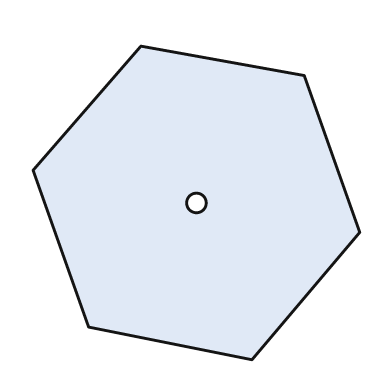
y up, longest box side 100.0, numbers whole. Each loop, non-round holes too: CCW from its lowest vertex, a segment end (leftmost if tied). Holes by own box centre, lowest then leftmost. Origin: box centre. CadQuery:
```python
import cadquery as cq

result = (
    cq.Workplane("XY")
    .moveTo(17.0, -48.0)
    .lineTo(50.0, -9.0)
    .lineTo(33.0, 39.0)
    .lineTo(-17.0, 48.0)
    .lineTo(-50.0, 10.0)
    .lineTo(-33.0, -38.0)
    .close()
    .moveTo(0.0, 0.0)
    .circle(3.0)
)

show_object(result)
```